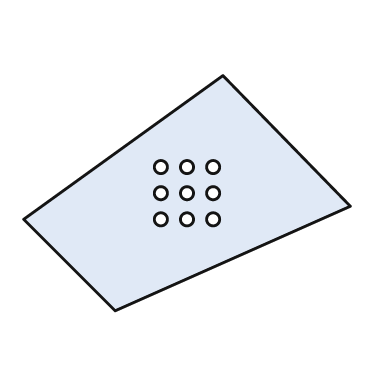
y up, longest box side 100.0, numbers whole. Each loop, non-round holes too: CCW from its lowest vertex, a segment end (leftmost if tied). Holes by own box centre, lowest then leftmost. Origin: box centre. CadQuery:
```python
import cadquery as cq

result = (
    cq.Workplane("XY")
    .moveTo(-22.0, -36.0)
    .lineTo(50.0, -4.0)
    .lineTo(11.0, 36.0)
    .lineTo(-50.0, -8.0)
    .close()
    .moveTo(-8.0, -8.0)
    .circle(2.0)
    .moveTo(0.0, -8.0)
    .circle(2.0)
    .moveTo(8.0, -8.0)
    .circle(2.0)
    .moveTo(-8.0, 0.0)
    .circle(2.0)
    .moveTo(0.0, 0.0)
    .circle(2.0)
    .moveTo(8.0, 0.0)
    .circle(2.0)
    .moveTo(-8.0, 8.0)
    .circle(2.0)
    .moveTo(0.0, 8.0)
    .circle(2.0)
    .moveTo(8.0, 8.0)
    .circle(2.0)
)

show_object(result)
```